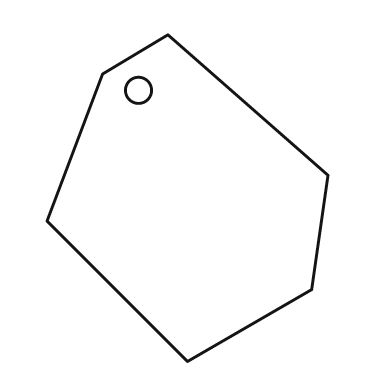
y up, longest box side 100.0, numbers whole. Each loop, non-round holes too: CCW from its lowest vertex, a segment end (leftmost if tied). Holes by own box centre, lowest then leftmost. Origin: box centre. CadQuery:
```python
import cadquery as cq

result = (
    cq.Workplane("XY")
    .moveTo(0.0, -50.0)
    .lineTo(38.0, -28.0)
    .lineTo(43.0, 7.0)
    .lineTo(-6.0, 50.0)
    .lineTo(-26.0, 38.0)
    .lineTo(-43.0, -7.0)
    .close()
    .moveTo(-15.0, 33.0)
    .circle(4.0)
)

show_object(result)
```